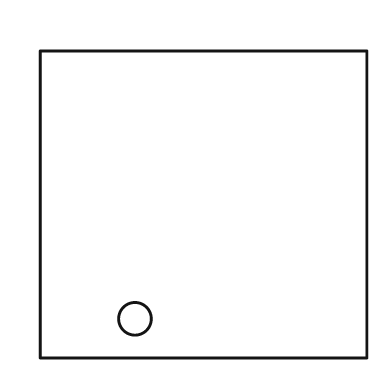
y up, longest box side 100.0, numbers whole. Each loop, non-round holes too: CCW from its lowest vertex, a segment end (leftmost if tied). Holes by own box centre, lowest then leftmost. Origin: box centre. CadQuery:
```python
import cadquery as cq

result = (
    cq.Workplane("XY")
    .moveTo(-50.0, -47.0)
    .lineTo(50.0, -47.0)
    .lineTo(50.0, 47.0)
    .lineTo(-50.0, 47.0)
    .close()
    .moveTo(-21.0, -35.0)
    .circle(5.0)
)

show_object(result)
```